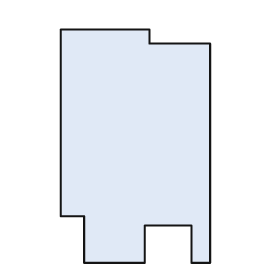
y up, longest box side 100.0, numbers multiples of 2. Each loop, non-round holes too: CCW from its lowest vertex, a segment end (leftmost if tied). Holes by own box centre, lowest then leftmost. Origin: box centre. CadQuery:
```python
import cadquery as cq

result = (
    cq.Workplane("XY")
    .moveTo(-22.0, -50.0)
    .lineTo(4.0, -50.0)
    .lineTo(4.0, -34.0)
    .lineTo(24.0, -34.0)
    .lineTo(24.0, -50.0)
    .lineTo(32.0, -50.0)
    .lineTo(32.0, 44.0)
    .lineTo(6.0, 44.0)
    .lineTo(6.0, 50.0)
    .lineTo(-32.0, 50.0)
    .lineTo(-32.0, -30.0)
    .lineTo(-22.0, -30.0)
    .close()
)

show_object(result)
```